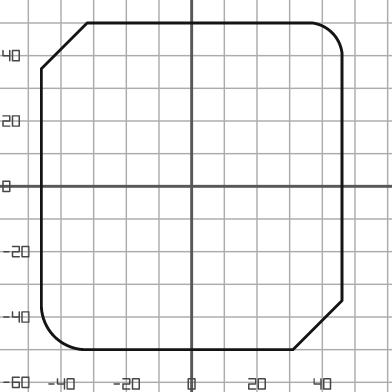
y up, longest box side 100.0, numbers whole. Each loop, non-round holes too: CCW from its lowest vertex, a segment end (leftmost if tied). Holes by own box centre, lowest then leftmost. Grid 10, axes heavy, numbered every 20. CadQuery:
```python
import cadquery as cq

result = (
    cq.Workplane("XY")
    .moveTo(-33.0, -50.0)
    .lineTo(31.0, -50.0)
    .lineTo(46.0, -35.0)
    .lineTo(46.0, 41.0)
    .threePointArc((43.0, 47.0), (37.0, 50.0))
    .lineTo(-32.0, 50.0)
    .lineTo(-46.0, 36.0)
    .lineTo(-46.0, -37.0)
    .threePointArc((-42.0, -46.0), (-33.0, -50.0))
    .close()
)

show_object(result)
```